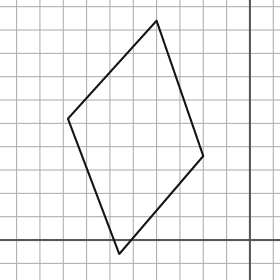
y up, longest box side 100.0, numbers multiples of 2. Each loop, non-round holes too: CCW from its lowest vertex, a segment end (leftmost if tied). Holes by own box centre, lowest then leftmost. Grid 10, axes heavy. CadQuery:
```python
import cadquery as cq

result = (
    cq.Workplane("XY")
    .moveTo(-56.0, -6.0)
    .lineTo(-20.0, 36.0)
    .lineTo(-40.0, 94.0)
    .lineTo(-78.0, 52.0)
    .close()
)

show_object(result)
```